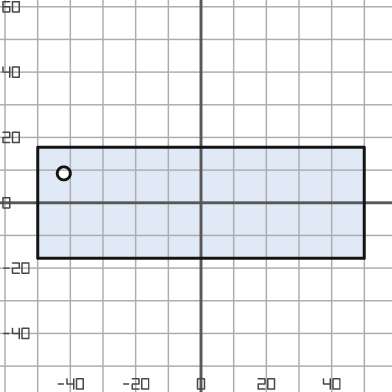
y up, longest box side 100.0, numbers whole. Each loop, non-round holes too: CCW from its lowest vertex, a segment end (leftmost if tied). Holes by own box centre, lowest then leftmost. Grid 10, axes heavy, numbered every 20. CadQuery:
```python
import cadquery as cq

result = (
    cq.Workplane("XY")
    .moveTo(-50.0, -17.0)
    .lineTo(50.0, -17.0)
    .lineTo(50.0, 17.0)
    .lineTo(-50.0, 17.0)
    .close()
    .moveTo(-42.0, 9.0)
    .circle(2.0)
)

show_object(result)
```